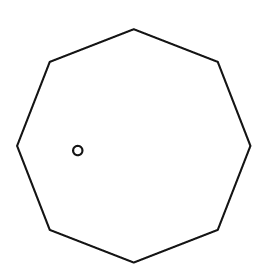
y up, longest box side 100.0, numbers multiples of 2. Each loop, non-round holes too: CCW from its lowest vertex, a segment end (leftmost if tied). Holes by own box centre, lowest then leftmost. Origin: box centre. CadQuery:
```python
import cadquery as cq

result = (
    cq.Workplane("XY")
    .moveTo(0.0, -50.0)
    .lineTo(36.0, -36.0)
    .lineTo(50.0, 0.0)
    .lineTo(36.0, 36.0)
    .lineTo(0.0, 50.0)
    .lineTo(-36.0, 36.0)
    .lineTo(-50.0, 0.0)
    .lineTo(-36.0, -36.0)
    .close()
    .moveTo(-24.0, -2.0)
    .circle(2.0)
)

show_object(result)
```